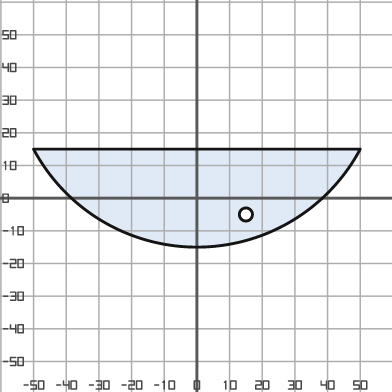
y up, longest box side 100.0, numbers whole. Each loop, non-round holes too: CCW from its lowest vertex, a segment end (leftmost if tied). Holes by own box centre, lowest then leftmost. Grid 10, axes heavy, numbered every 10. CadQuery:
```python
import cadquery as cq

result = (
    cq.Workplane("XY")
    .moveTo(-50.0, 15.0)
    .threePointArc((0.0, -15.0), (50.0, 15.0))
    .close()
    .moveTo(15.0, -5.0)
    .circle(2.0)
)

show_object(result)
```